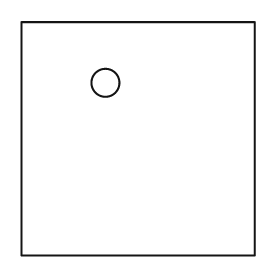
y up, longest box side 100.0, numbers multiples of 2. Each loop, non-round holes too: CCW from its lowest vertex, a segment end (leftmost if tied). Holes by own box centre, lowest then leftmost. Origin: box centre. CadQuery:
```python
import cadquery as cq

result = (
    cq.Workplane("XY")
    .moveTo(-50.0, -50.0)
    .lineTo(50.0, -50.0)
    .lineTo(50.0, 50.0)
    .lineTo(-50.0, 50.0)
    .close()
    .moveTo(-14.0, 24.0)
    .circle(6.0)
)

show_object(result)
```